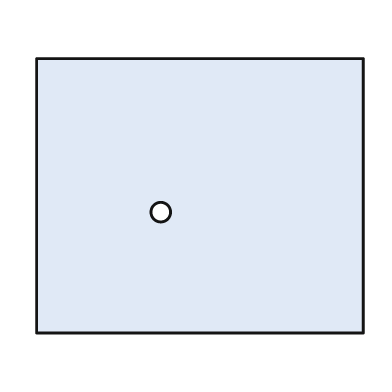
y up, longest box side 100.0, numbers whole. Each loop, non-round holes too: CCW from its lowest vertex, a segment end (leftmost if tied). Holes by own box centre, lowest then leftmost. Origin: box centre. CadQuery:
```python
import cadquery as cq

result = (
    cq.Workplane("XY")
    .moveTo(-50.0, -42.0)
    .lineTo(50.0, -42.0)
    .lineTo(50.0, 42.0)
    .lineTo(-50.0, 42.0)
    .close()
    .moveTo(-12.0, -5.0)
    .circle(3.0)
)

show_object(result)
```